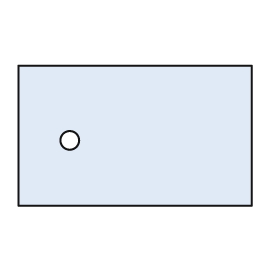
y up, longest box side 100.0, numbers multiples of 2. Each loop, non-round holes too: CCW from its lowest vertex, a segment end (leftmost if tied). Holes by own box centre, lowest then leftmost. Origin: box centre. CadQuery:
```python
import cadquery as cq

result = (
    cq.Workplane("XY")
    .moveTo(-50.0, -30.0)
    .lineTo(50.0, -30.0)
    .lineTo(50.0, 30.0)
    .lineTo(-50.0, 30.0)
    .close()
    .moveTo(-28.0, -2.0)
    .circle(4.0)
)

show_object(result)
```